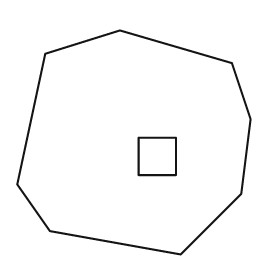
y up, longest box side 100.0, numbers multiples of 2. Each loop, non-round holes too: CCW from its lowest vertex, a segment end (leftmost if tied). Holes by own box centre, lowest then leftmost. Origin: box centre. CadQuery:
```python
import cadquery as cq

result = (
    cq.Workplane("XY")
    .moveTo(20.0, -48.0)
    .lineTo(46.0, -22.0)
    .lineTo(50.0, 10.0)
    .lineTo(42.0, 34.0)
    .lineTo(-6.0, 48.0)
    .lineTo(-38.0, 38.0)
    .lineTo(-50.0, -18.0)
    .lineTo(-36.0, -38.0)
    .close()
    .moveTo(2.0, -14.0)
    .lineTo(18.0, -14.0)
    .lineTo(18.0, 2.0)
    .lineTo(2.0, 2.0)
    .close()
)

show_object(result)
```